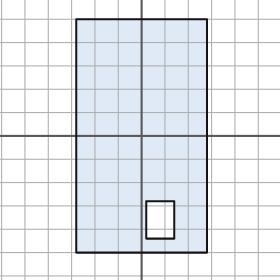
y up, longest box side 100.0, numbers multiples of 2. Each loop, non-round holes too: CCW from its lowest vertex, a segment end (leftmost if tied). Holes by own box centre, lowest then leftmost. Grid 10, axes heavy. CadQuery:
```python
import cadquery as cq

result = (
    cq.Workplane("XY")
    .moveTo(-28.0, -50.0)
    .lineTo(28.0, -50.0)
    .lineTo(28.0, 50.0)
    .lineTo(-28.0, 50.0)
    .close()
    .moveTo(2.0, -44.0)
    .lineTo(14.0, -44.0)
    .lineTo(14.0, -28.0)
    .lineTo(2.0, -28.0)
    .close()
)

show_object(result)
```